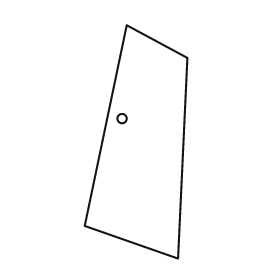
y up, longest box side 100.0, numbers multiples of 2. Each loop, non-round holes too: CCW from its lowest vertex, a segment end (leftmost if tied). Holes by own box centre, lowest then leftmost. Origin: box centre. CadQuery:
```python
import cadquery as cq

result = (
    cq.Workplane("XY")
    .moveTo(18.0, -50.0)
    .lineTo(22.0, 36.0)
    .lineTo(-4.0, 50.0)
    .lineTo(-22.0, -36.0)
    .close()
    .moveTo(-6.0, 10.0)
    .circle(2.0)
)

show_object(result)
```